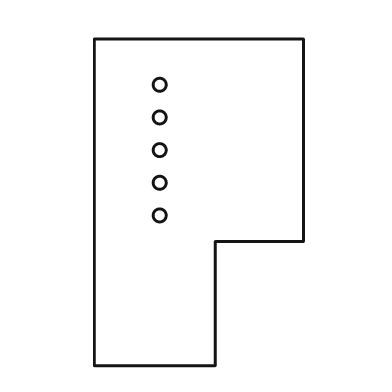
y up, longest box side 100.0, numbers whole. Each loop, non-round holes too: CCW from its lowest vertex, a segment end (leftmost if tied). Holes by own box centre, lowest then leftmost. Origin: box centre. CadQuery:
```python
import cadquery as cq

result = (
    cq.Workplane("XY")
    .moveTo(-32.0, -50.0)
    .lineTo(5.0, -50.0)
    .lineTo(5.0, -12.0)
    .lineTo(32.0, -12.0)
    .lineTo(32.0, 50.0)
    .lineTo(-32.0, 50.0)
    .close()
    .moveTo(-12.0, -4.0)
    .circle(2.0)
    .moveTo(-12.0, 6.0)
    .circle(2.0)
    .moveTo(-12.0, 16.0)
    .circle(2.0)
    .moveTo(-12.0, 26.0)
    .circle(2.0)
    .moveTo(-12.0, 36.0)
    .circle(2.0)
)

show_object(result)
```